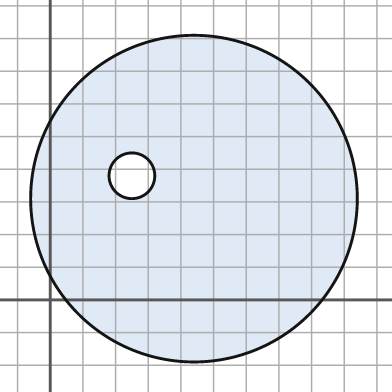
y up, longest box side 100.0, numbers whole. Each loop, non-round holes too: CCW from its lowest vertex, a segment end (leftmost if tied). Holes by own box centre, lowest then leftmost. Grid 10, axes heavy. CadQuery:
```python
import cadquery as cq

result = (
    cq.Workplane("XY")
    .moveTo(44.0, 31.0)
    .circle(50.0)
    .moveTo(25.0, 38.0)
    .circle(7.0)
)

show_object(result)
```